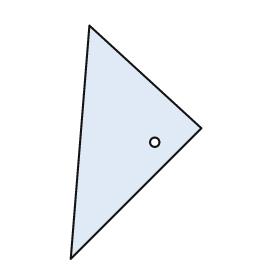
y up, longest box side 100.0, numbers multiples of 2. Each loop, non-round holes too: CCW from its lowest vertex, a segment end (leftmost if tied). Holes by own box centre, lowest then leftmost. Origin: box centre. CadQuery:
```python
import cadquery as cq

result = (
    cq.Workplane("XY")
    .moveTo(-28.0, -50.0)
    .lineTo(28.0, 6.0)
    .lineTo(-20.0, 50.0)
    .close()
    .moveTo(8.0, 0.0)
    .circle(2.0)
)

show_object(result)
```